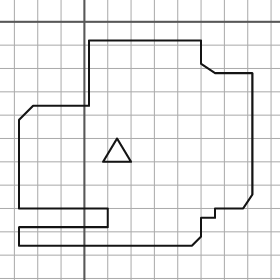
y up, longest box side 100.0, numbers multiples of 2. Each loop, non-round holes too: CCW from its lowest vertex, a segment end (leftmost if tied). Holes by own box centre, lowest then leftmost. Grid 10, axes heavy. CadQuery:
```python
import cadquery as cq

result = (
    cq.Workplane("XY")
    .moveTo(-28.0, -96.0)
    .lineTo(46.0, -96.0)
    .lineTo(50.0, -92.0)
    .lineTo(50.0, -84.0)
    .lineTo(56.0, -84.0)
    .lineTo(56.0, -80.0)
    .lineTo(68.0, -80.0)
    .lineTo(72.0, -74.0)
    .lineTo(72.0, -22.0)
    .lineTo(56.0, -22.0)
    .lineTo(50.0, -18.0)
    .lineTo(50.0, -8.0)
    .lineTo(2.0, -8.0)
    .lineTo(2.0, -36.0)
    .lineTo(-22.0, -36.0)
    .lineTo(-28.0, -42.0)
    .lineTo(-28.0, -80.0)
    .lineTo(10.0, -80.0)
    .lineTo(10.0, -88.0)
    .lineTo(-28.0, -88.0)
    .close()
    .moveTo(8.0, -60.0)
    .lineTo(20.0, -60.0)
    .lineTo(14.0, -50.0)
    .close()
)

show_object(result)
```